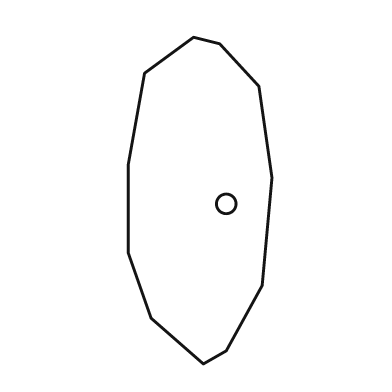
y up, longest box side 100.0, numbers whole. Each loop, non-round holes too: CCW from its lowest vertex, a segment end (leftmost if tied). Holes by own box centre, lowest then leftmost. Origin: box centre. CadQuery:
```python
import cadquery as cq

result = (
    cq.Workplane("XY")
    .moveTo(1.0, -50.0)
    .lineTo(8.0, -46.0)
    .lineTo(19.0, -26.0)
    .lineTo(22.0, 7.0)
    .lineTo(18.0, 35.0)
    .lineTo(6.0, 48.0)
    .lineTo(-2.0, 50.0)
    .lineTo(-17.0, 39.0)
    .lineTo(-22.0, 11.0)
    .lineTo(-22.0, -16.0)
    .lineTo(-15.0, -36.0)
    .close()
    .moveTo(8.0, -1.0)
    .circle(3.0)
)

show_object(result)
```